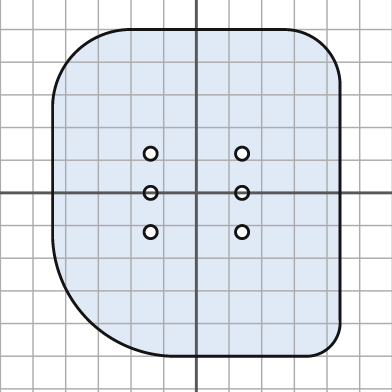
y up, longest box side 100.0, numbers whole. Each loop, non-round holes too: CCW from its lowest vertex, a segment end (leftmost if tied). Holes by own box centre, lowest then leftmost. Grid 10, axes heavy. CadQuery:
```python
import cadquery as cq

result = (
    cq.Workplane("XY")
    .moveTo(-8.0, -50.0)
    .lineTo(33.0, -50.0)
    .threePointArc((41.0, -47.0), (44.0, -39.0))
    .lineTo(44.0, 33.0)
    .threePointArc((39.0, 45.0), (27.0, 50.0))
    .lineTo(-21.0, 50.0)
    .threePointArc((-37.0, 43.0), (-44.0, 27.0))
    .lineTo(-44.0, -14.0)
    .threePointArc((-33.0, -39.0), (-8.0, -50.0))
    .close()
    .moveTo(-14.0, -12.0)
    .circle(2.0)
    .moveTo(14.0, -12.0)
    .circle(2.0)
    .moveTo(-14.0, 0.0)
    .circle(2.0)
    .moveTo(14.0, 0.0)
    .circle(2.0)
    .moveTo(-14.0, 12.0)
    .circle(2.0)
    .moveTo(14.0, 12.0)
    .circle(2.0)
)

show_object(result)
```